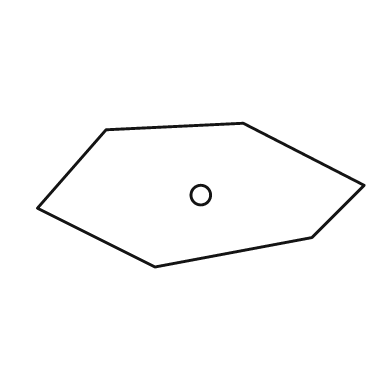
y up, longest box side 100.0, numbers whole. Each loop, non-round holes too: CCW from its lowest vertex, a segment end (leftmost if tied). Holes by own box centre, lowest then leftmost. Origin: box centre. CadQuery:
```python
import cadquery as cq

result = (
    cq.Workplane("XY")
    .moveTo(-14.0, -22.0)
    .lineTo(34.0, -13.0)
    .lineTo(50.0, 3.0)
    .lineTo(13.0, 22.0)
    .lineTo(-29.0, 20.0)
    .lineTo(-50.0, -4.0)
    .close()
    .moveTo(0.0, 0.0)
    .circle(3.0)
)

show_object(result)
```